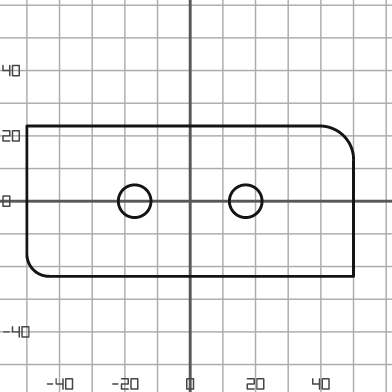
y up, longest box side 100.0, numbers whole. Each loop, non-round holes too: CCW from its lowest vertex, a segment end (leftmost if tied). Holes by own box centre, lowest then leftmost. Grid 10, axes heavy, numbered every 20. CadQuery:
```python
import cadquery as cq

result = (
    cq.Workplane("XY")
    .moveTo(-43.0, -23.0)
    .lineTo(50.0, -23.0)
    .lineTo(50.0, 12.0)
    .threePointArc((47.0, 20.0), (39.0, 23.0))
    .lineTo(-50.0, 23.0)
    .lineTo(-50.0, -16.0)
    .threePointArc((-48.0, -21.0), (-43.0, -23.0))
    .close()
    .moveTo(-17.0, 0.0)
    .circle(5.0)
    .moveTo(17.0, 0.0)
    .circle(5.0)
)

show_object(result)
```